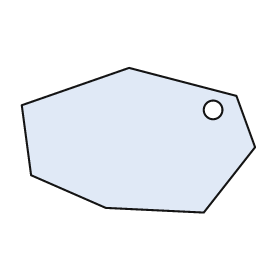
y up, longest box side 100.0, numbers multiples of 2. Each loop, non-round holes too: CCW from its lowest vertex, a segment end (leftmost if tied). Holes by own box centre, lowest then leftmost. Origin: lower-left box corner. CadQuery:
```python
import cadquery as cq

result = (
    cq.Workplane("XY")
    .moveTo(78.0, 0.0)
    .lineTo(100.0, 28.0)
    .lineTo(92.0, 50.0)
    .lineTo(46.0, 62.0)
    .lineTo(0.0, 46.0)
    .lineTo(4.0, 16.0)
    .lineTo(36.0, 2.0)
    .close()
    .moveTo(82.0, 44.0)
    .circle(4.0)
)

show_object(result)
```